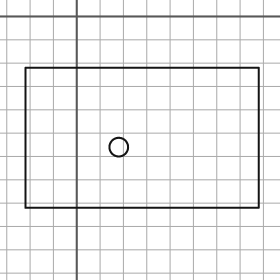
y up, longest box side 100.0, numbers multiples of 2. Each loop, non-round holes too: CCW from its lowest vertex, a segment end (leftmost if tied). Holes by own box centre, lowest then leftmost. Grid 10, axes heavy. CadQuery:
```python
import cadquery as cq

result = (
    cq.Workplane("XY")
    .moveTo(-22.0, -82.0)
    .lineTo(78.0, -82.0)
    .lineTo(78.0, -22.0)
    .lineTo(-22.0, -22.0)
    .close()
    .moveTo(18.0, -56.0)
    .circle(4.0)
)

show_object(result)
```